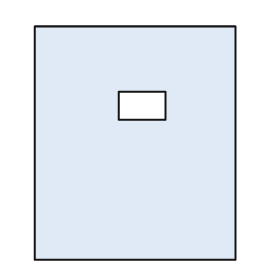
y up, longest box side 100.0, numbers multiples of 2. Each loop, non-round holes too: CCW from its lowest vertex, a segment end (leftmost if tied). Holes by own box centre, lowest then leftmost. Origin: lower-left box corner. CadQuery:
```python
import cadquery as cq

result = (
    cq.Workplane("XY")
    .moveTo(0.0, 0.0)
    .lineTo(86.0, 0.0)
    .lineTo(86.0, 100.0)
    .lineTo(0.0, 100.0)
    .close()
    .moveTo(36.0, 60.0)
    .lineTo(56.0, 60.0)
    .lineTo(56.0, 72.0)
    .lineTo(36.0, 72.0)
    .close()
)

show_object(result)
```